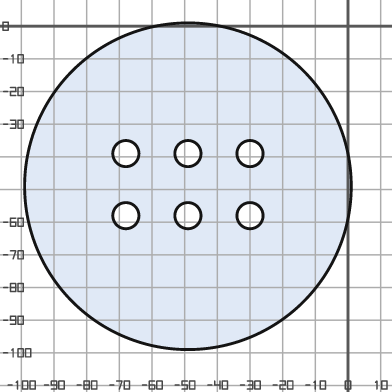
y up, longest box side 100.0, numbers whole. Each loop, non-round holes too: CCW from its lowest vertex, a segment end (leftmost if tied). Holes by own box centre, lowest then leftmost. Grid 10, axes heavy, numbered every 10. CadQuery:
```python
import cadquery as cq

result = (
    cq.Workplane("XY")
    .moveTo(-49.0, -49.0)
    .circle(50.0)
    .moveTo(-68.0, -58.0)
    .circle(4.0)
    .moveTo(-49.0, -58.0)
    .circle(4.0)
    .moveTo(-30.0, -58.0)
    .circle(4.0)
    .moveTo(-68.0, -39.0)
    .circle(4.0)
    .moveTo(-49.0, -39.0)
    .circle(4.0)
    .moveTo(-30.0, -39.0)
    .circle(4.0)
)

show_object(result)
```